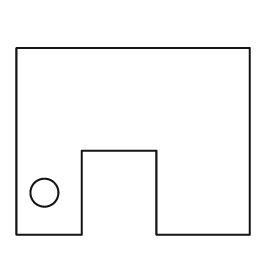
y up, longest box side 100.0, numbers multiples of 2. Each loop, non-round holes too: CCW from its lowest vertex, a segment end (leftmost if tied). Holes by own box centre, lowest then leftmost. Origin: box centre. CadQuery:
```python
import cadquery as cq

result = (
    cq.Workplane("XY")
    .moveTo(-50.0, -40.0)
    .lineTo(-22.0, -40.0)
    .lineTo(-22.0, -4.0)
    .lineTo(10.0, -4.0)
    .lineTo(10.0, -40.0)
    .lineTo(50.0, -40.0)
    .lineTo(50.0, 40.0)
    .lineTo(-50.0, 40.0)
    .close()
    .moveTo(-38.0, -22.0)
    .circle(6.0)
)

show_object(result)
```